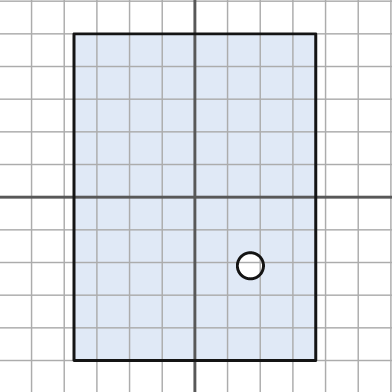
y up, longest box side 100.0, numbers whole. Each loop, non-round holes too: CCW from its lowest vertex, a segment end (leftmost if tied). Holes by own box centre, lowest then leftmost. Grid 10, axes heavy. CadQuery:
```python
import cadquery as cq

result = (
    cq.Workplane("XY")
    .moveTo(-37.0, -50.0)
    .lineTo(37.0, -50.0)
    .lineTo(37.0, 50.0)
    .lineTo(-37.0, 50.0)
    .close()
    .moveTo(17.0, -21.0)
    .circle(4.0)
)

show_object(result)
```